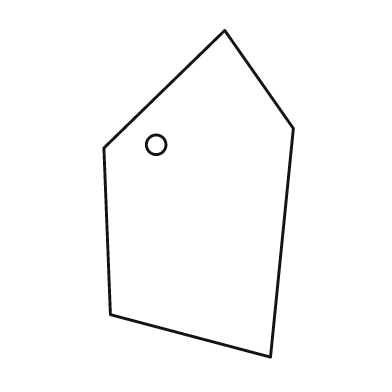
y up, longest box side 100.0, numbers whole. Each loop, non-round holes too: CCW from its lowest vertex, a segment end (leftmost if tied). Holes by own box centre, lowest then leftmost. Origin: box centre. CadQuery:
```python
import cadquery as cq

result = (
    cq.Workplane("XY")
    .moveTo(22.0, -50.0)
    .lineTo(29.0, 20.0)
    .lineTo(8.0, 50.0)
    .lineTo(-29.0, 14.0)
    .lineTo(-27.0, -37.0)
    .close()
    .moveTo(-13.0, 15.0)
    .circle(3.0)
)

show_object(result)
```